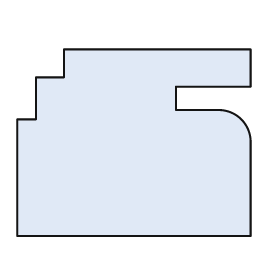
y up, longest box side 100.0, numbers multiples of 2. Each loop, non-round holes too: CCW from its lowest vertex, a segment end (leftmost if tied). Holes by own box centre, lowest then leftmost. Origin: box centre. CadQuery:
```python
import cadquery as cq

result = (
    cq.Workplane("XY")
    .moveTo(-50.0, -40.0)
    .lineTo(50.0, -40.0)
    .lineTo(50.0, 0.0)
    .threePointArc((46.0, 10.0), (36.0, 14.0))
    .lineTo(18.0, 14.0)
    .lineTo(18.0, 24.0)
    .lineTo(50.0, 24.0)
    .lineTo(50.0, 40.0)
    .lineTo(-30.0, 40.0)
    .lineTo(-30.0, 28.0)
    .lineTo(-42.0, 28.0)
    .lineTo(-42.0, 10.0)
    .lineTo(-50.0, 10.0)
    .close()
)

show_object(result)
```